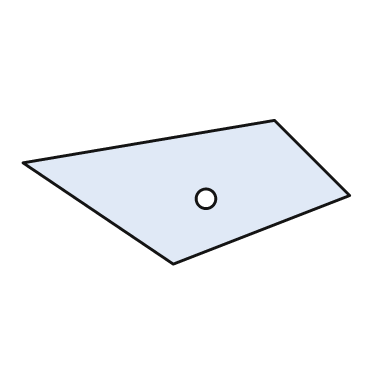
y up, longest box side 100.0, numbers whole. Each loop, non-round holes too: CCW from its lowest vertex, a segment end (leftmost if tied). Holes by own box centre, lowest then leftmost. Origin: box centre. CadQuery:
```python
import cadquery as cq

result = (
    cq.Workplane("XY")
    .moveTo(-4.0, -22.0)
    .lineTo(50.0, -1.0)
    .lineTo(27.0, 22.0)
    .lineTo(-50.0, 9.0)
    .close()
    .moveTo(6.0, -2.0)
    .circle(3.0)
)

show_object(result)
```